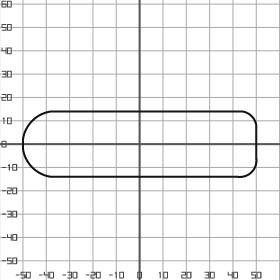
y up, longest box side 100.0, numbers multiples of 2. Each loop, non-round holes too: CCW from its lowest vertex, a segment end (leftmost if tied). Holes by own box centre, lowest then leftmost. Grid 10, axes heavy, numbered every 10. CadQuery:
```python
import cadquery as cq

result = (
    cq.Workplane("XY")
    .moveTo(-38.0, -14.0)
    .lineTo(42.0, -14.0)
    .threePointArc((48.0, -12.0), (50.0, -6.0))
    .lineTo(50.0, 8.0)
    .threePointArc((48.0, 12.0), (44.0, 14.0))
    .lineTo(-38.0, 14.0)
    .threePointArc((-46.0, 10.0), (-50.0, 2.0))
    .lineTo(-50.0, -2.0)
    .threePointArc((-46.0, -10.0), (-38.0, -14.0))
    .close()
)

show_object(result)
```